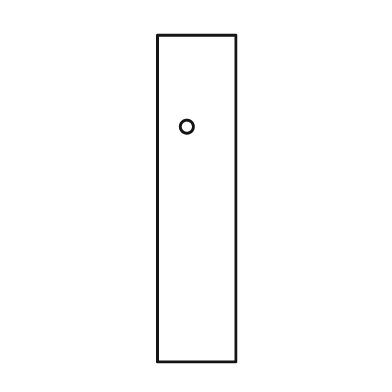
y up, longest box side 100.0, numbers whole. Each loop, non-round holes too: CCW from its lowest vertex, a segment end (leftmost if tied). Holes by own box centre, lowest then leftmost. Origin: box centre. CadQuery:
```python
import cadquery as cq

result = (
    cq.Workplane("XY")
    .moveTo(-12.0, -50.0)
    .lineTo(12.0, -50.0)
    .lineTo(12.0, 50.0)
    .lineTo(-12.0, 50.0)
    .close()
    .moveTo(-3.0, 22.0)
    .circle(2.0)
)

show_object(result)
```